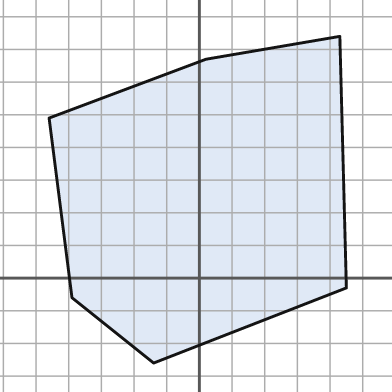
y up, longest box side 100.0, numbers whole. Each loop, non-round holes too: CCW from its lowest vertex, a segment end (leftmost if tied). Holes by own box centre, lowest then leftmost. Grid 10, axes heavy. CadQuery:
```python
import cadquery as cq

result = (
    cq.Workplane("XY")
    .moveTo(-14.0, -26.0)
    .lineTo(45.0, -3.0)
    .lineTo(43.0, 74.0)
    .lineTo(2.0, 67.0)
    .lineTo(-46.0, 49.0)
    .lineTo(-39.0, -6.0)
    .close()
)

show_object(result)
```